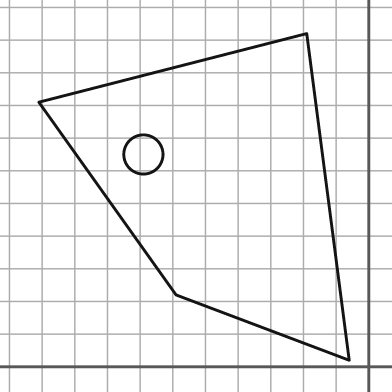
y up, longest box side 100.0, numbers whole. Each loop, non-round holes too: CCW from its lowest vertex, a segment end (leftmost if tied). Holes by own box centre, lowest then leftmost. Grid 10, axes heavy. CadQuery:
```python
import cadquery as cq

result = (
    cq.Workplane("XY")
    .moveTo(-6.0, 2.0)
    .lineTo(-19.0, 102.0)
    .lineTo(-101.0, 81.0)
    .lineTo(-59.0, 22.0)
    .close()
    .moveTo(-69.0, 65.0)
    .circle(6.0)
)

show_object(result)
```